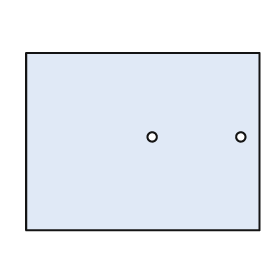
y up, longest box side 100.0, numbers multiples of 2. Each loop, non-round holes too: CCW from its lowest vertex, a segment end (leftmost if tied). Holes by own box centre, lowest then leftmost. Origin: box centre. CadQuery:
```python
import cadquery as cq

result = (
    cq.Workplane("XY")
    .moveTo(-50.0, -38.0)
    .lineTo(50.0, -38.0)
    .lineTo(50.0, 38.0)
    .lineTo(-50.0, 38.0)
    .close()
    .moveTo(4.0, 2.0)
    .circle(2.0)
    .moveTo(42.0, 2.0)
    .circle(2.0)
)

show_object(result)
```